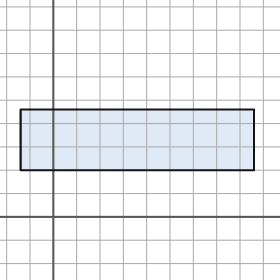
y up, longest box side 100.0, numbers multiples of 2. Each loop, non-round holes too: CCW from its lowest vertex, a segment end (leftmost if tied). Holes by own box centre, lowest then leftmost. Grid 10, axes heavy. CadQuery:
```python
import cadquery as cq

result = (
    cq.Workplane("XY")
    .moveTo(-14.0, 20.0)
    .lineTo(86.0, 20.0)
    .lineTo(86.0, 46.0)
    .lineTo(-14.0, 46.0)
    .close()
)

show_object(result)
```